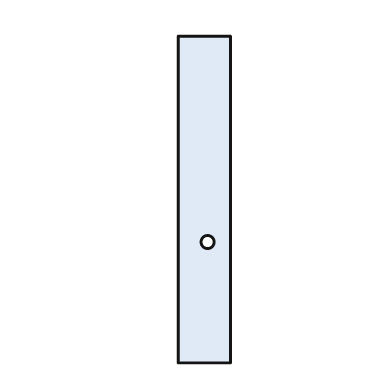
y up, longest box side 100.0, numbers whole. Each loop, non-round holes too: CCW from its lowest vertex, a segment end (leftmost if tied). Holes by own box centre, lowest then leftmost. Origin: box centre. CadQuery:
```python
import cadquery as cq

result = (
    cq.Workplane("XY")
    .moveTo(-8.0, -50.0)
    .lineTo(8.0, -50.0)
    .lineTo(8.0, 50.0)
    .lineTo(-8.0, 50.0)
    .close()
    .moveTo(1.0, -13.0)
    .circle(2.0)
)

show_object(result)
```